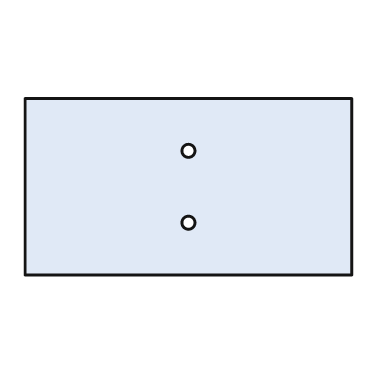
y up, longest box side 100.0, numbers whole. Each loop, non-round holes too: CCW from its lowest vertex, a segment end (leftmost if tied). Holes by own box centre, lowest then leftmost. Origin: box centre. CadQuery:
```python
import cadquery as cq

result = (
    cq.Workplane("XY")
    .moveTo(-50.0, -27.0)
    .lineTo(50.0, -27.0)
    .lineTo(50.0, 27.0)
    .lineTo(-50.0, 27.0)
    .close()
    .moveTo(0.0, -11.0)
    .circle(2.0)
    .moveTo(0.0, 11.0)
    .circle(2.0)
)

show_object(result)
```